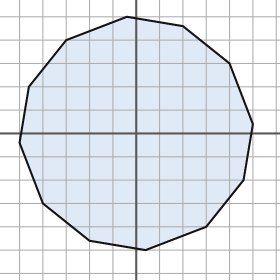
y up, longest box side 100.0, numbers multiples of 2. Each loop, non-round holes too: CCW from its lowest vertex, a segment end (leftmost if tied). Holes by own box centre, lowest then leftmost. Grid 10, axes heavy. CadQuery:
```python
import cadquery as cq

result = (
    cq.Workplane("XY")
    .moveTo(4.0, -50.0)
    .lineTo(30.0, -40.0)
    .lineTo(46.0, -20.0)
    .lineTo(50.0, 4.0)
    .lineTo(40.0, 30.0)
    .lineTo(20.0, 46.0)
    .lineTo(-4.0, 50.0)
    .lineTo(-30.0, 40.0)
    .lineTo(-46.0, 20.0)
    .lineTo(-50.0, -4.0)
    .lineTo(-40.0, -30.0)
    .lineTo(-20.0, -46.0)
    .close()
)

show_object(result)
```